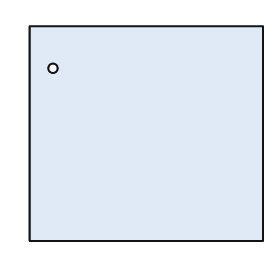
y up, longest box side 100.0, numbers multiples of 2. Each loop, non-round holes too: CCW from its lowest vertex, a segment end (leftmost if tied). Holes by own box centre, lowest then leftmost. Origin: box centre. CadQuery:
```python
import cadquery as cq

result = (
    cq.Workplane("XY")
    .moveTo(-50.0, -46.0)
    .lineTo(50.0, -46.0)
    .lineTo(50.0, 46.0)
    .lineTo(-50.0, 46.0)
    .close()
    .moveTo(-40.0, 28.0)
    .circle(2.0)
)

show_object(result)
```